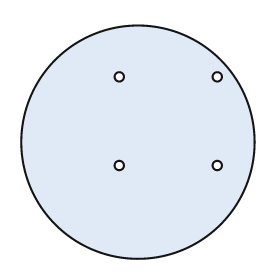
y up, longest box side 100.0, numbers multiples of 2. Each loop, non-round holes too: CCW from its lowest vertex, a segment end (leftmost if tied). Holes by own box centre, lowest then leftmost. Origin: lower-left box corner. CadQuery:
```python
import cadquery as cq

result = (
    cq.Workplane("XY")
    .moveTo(50.0, 50.0)
    .circle(50.0)
    .moveTo(42.0, 40.0)
    .circle(2.0)
    .moveTo(84.0, 40.0)
    .circle(2.0)
    .moveTo(42.0, 78.0)
    .circle(2.0)
    .moveTo(84.0, 78.0)
    .circle(2.0)
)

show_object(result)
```